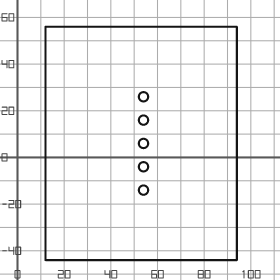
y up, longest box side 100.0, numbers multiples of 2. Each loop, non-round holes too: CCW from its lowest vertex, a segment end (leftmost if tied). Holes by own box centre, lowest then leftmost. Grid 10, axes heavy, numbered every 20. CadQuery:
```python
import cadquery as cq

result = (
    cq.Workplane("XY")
    .moveTo(12.0, -44.0)
    .lineTo(94.0, -44.0)
    .lineTo(94.0, 56.0)
    .lineTo(12.0, 56.0)
    .close()
    .moveTo(54.0, -14.0)
    .circle(2.0)
    .moveTo(54.0, -4.0)
    .circle(2.0)
    .moveTo(54.0, 6.0)
    .circle(2.0)
    .moveTo(54.0, 16.0)
    .circle(2.0)
    .moveTo(54.0, 26.0)
    .circle(2.0)
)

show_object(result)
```